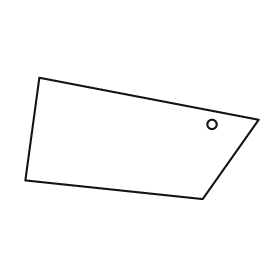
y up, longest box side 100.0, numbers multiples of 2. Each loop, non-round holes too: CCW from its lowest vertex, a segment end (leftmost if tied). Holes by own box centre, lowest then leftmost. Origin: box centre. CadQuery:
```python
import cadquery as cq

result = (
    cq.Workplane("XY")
    .moveTo(26.0, -26.0)
    .lineTo(50.0, 8.0)
    .lineTo(-44.0, 26.0)
    .lineTo(-50.0, -18.0)
    .close()
    .moveTo(30.0, 6.0)
    .circle(2.0)
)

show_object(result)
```